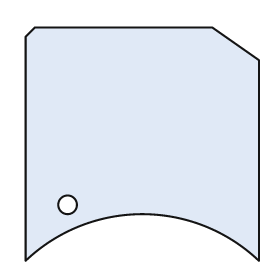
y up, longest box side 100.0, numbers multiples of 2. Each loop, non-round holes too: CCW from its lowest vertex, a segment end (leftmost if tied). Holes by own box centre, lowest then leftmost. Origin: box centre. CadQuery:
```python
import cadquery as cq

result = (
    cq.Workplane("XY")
    .moveTo(-50.0, -50.0)
    .threePointArc((0.0, -30.0), (50.0, -50.0))
    .lineTo(50.0, 36.0)
    .lineTo(30.0, 50.0)
    .lineTo(-46.0, 50.0)
    .lineTo(-50.0, 46.0)
    .close()
    .moveTo(-32.0, -26.0)
    .circle(4.0)
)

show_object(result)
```